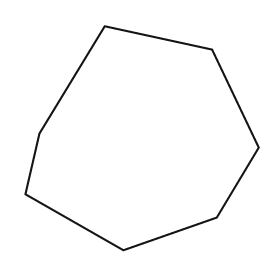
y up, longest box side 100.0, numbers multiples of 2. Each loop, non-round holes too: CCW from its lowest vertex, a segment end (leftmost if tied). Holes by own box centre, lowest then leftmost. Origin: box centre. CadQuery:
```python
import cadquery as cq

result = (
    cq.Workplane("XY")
    .moveTo(-8.0, -48.0)
    .lineTo(32.0, -34.0)
    .lineTo(50.0, -4.0)
    .lineTo(30.0, 38.0)
    .lineTo(-16.0, 48.0)
    .lineTo(-44.0, 2.0)
    .lineTo(-50.0, -24.0)
    .close()
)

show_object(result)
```